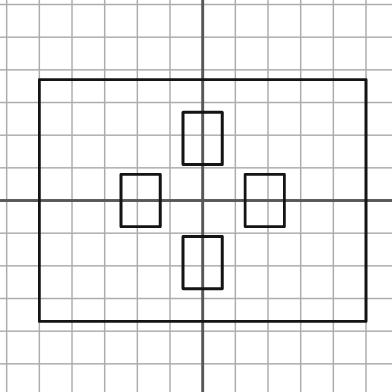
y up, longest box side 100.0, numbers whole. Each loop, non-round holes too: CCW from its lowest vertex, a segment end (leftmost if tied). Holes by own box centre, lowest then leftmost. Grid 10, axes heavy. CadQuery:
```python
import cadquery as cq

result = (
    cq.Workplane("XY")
    .moveTo(-50.0, -37.0)
    .lineTo(50.0, -37.0)
    .lineTo(50.0, 37.0)
    .lineTo(-50.0, 37.0)
    .close()
    .moveTo(-6.0, -27.0)
    .lineTo(6.0, -27.0)
    .lineTo(6.0, -11.0)
    .lineTo(-6.0, -11.0)
    .close()
    .moveTo(-25.0, -8.0)
    .lineTo(-13.0, -8.0)
    .lineTo(-13.0, 8.0)
    .lineTo(-25.0, 8.0)
    .close()
    .moveTo(13.0, -8.0)
    .lineTo(25.0, -8.0)
    .lineTo(25.0, 8.0)
    .lineTo(13.0, 8.0)
    .close()
    .moveTo(-6.0, 11.0)
    .lineTo(6.0, 11.0)
    .lineTo(6.0, 27.0)
    .lineTo(-6.0, 27.0)
    .close()
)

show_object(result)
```